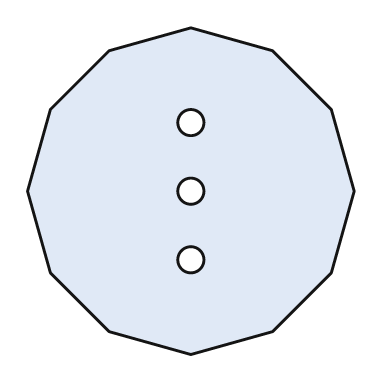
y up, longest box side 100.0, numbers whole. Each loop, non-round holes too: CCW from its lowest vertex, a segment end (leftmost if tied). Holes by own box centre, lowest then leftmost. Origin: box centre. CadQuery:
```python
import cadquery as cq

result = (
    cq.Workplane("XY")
    .moveTo(0.0, -50.0)
    .lineTo(25.0, -43.0)
    .lineTo(43.0, -25.0)
    .lineTo(50.0, 0.0)
    .lineTo(43.0, 25.0)
    .lineTo(25.0, 43.0)
    .lineTo(0.0, 50.0)
    .lineTo(-25.0, 43.0)
    .lineTo(-43.0, 25.0)
    .lineTo(-50.0, 0.0)
    .lineTo(-43.0, -25.0)
    .lineTo(-25.0, -43.0)
    .close()
    .moveTo(0.0, -21.0)
    .circle(4.0)
    .moveTo(0.0, 0.0)
    .circle(4.0)
    .moveTo(0.0, 21.0)
    .circle(4.0)
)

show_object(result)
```